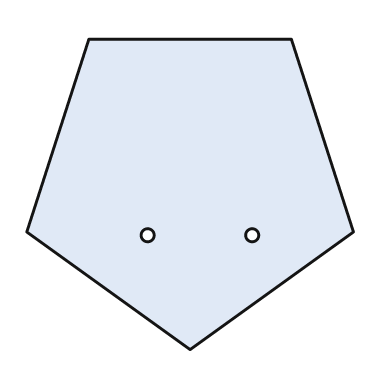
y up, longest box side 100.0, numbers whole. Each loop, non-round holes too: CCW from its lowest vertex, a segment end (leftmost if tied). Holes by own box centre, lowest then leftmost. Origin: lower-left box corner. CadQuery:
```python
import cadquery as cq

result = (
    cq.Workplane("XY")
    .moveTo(50.0, 0.0)
    .lineTo(100.0, 36.0)
    .lineTo(81.0, 95.0)
    .lineTo(19.0, 95.0)
    .lineTo(0.0, 36.0)
    .close()
    .moveTo(37.0, 35.0)
    .circle(2.0)
    .moveTo(69.0, 35.0)
    .circle(2.0)
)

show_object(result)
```